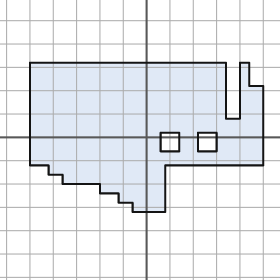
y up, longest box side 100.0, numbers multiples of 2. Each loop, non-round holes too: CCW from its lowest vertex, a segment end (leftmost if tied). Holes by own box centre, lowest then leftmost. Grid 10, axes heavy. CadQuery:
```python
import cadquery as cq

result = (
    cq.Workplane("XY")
    .moveTo(-6.0, -32.0)
    .lineTo(8.0, -32.0)
    .lineTo(8.0, -12.0)
    .lineTo(50.0, -12.0)
    .lineTo(50.0, 22.0)
    .lineTo(44.0, 22.0)
    .lineTo(44.0, 32.0)
    .lineTo(40.0, 32.0)
    .lineTo(40.0, 8.0)
    .lineTo(34.0, 8.0)
    .lineTo(34.0, 32.0)
    .lineTo(-50.0, 32.0)
    .lineTo(-50.0, -12.0)
    .lineTo(-42.0, -12.0)
    .lineTo(-42.0, -16.0)
    .lineTo(-36.0, -16.0)
    .lineTo(-36.0, -20.0)
    .lineTo(-20.0, -20.0)
    .lineTo(-20.0, -24.0)
    .lineTo(-12.0, -24.0)
    .lineTo(-12.0, -28.0)
    .lineTo(-6.0, -28.0)
    .close()
    .moveTo(6.0, -6.0)
    .lineTo(14.0, -6.0)
    .lineTo(14.0, 2.0)
    .lineTo(6.0, 2.0)
    .close()
    .moveTo(22.0, -6.0)
    .lineTo(30.0, -6.0)
    .lineTo(30.0, 2.0)
    .lineTo(22.0, 2.0)
    .close()
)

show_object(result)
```